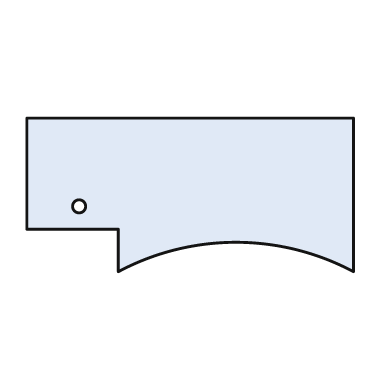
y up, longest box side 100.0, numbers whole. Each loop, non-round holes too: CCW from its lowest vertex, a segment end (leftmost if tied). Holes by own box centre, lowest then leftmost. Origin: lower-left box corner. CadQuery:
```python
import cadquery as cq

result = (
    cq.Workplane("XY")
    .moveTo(28.0, 0.0)
    .threePointArc((64.0, 9.0), (100.0, 0.0))
    .lineTo(100.0, 47.0)
    .lineTo(0.0, 47.0)
    .lineTo(0.0, 13.0)
    .lineTo(28.0, 13.0)
    .close()
    .moveTo(16.0, 20.0)
    .circle(2.0)
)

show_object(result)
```